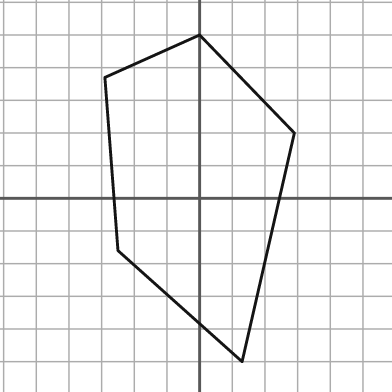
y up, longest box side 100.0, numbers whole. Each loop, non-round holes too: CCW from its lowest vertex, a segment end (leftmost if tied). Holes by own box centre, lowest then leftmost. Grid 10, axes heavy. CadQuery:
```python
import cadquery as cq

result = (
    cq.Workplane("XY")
    .moveTo(13.0, -50.0)
    .lineTo(29.0, 20.0)
    .lineTo(0.0, 50.0)
    .lineTo(-29.0, 37.0)
    .lineTo(-25.0, -16.0)
    .close()
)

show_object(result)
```